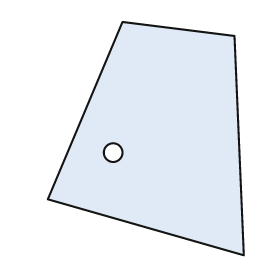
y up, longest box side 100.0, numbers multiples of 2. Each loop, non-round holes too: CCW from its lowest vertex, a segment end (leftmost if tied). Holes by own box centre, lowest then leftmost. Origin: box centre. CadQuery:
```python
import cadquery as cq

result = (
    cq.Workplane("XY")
    .moveTo(42.0, -50.0)
    .lineTo(38.0, 44.0)
    .lineTo(-10.0, 50.0)
    .lineTo(-42.0, -26.0)
    .close()
    .moveTo(-14.0, -6.0)
    .circle(4.0)
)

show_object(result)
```